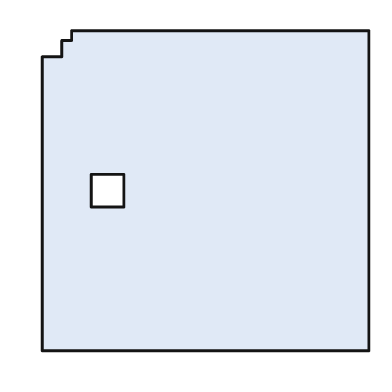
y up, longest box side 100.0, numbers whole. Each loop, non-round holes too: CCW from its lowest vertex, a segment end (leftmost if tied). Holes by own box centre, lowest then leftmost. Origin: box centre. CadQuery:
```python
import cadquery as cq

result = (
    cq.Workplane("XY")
    .moveTo(-50.0, -49.0)
    .lineTo(50.0, -49.0)
    .lineTo(50.0, 49.0)
    .lineTo(-41.0, 49.0)
    .lineTo(-41.0, 46.0)
    .lineTo(-44.0, 46.0)
    .lineTo(-44.0, 41.0)
    .lineTo(-50.0, 41.0)
    .close()
    .moveTo(-35.0, -5.0)
    .lineTo(-25.0, -5.0)
    .lineTo(-25.0, 5.0)
    .lineTo(-35.0, 5.0)
    .close()
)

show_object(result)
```